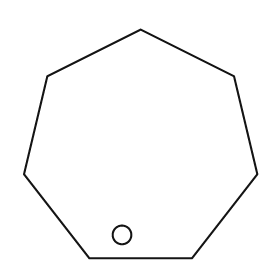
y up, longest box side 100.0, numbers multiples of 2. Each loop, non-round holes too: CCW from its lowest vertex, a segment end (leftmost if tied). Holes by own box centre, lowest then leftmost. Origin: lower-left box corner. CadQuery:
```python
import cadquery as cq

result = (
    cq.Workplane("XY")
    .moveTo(28.0, 0.0)
    .lineTo(72.0, 0.0)
    .lineTo(100.0, 36.0)
    .lineTo(90.0, 78.0)
    .lineTo(50.0, 98.0)
    .lineTo(10.0, 78.0)
    .lineTo(0.0, 36.0)
    .close()
    .moveTo(42.0, 10.0)
    .circle(4.0)
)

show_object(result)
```